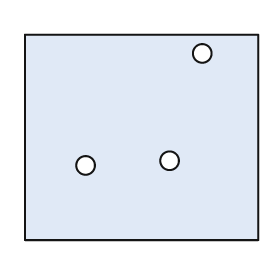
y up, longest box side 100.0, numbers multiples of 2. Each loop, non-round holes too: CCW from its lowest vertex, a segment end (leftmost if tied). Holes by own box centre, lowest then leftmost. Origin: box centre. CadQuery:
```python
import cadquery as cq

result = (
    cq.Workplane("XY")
    .moveTo(-50.0, -44.0)
    .lineTo(50.0, -44.0)
    .lineTo(50.0, 44.0)
    .lineTo(-50.0, 44.0)
    .close()
    .moveTo(-24.0, -12.0)
    .circle(4.0)
    .moveTo(12.0, -10.0)
    .circle(4.0)
    .moveTo(26.0, 36.0)
    .circle(4.0)
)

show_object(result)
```